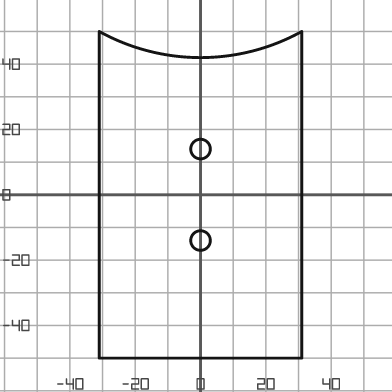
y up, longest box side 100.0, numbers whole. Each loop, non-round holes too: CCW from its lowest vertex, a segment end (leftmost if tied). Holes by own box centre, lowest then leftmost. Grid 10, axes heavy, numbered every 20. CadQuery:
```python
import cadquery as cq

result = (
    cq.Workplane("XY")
    .moveTo(-31.0, -50.0)
    .lineTo(31.0, -50.0)
    .lineTo(31.0, 50.0)
    .threePointArc((0.0, 42.0), (-31.0, 50.0))
    .close()
    .moveTo(0.0, -14.0)
    .circle(3.0)
    .moveTo(0.0, 14.0)
    .circle(3.0)
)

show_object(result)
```